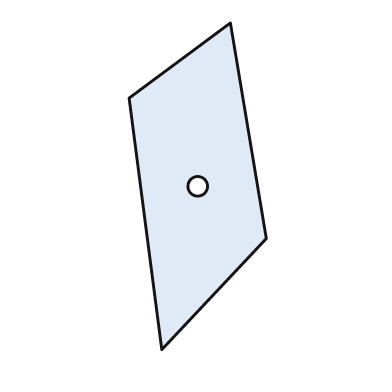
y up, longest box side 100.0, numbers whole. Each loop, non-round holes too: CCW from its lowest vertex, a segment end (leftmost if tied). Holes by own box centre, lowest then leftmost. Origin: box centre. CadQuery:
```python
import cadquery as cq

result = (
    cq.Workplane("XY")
    .moveTo(-11.0, -50.0)
    .lineTo(21.0, -16.0)
    .lineTo(10.0, 50.0)
    .lineTo(-21.0, 27.0)
    .close()
    .moveTo(0.0, 0.0)
    .circle(3.0)
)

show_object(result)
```